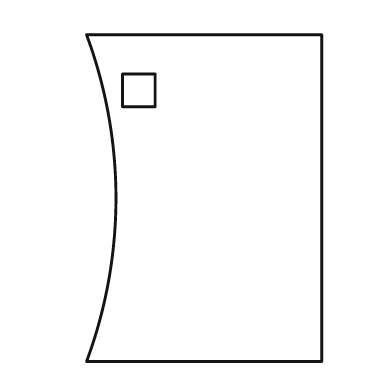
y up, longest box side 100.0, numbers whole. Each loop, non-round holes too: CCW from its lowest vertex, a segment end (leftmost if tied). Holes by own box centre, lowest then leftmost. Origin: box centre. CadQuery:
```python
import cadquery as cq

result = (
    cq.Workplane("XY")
    .moveTo(-36.0, -50.0)
    .lineTo(36.0, -50.0)
    .lineTo(36.0, 50.0)
    .lineTo(-36.0, 50.0)
    .threePointArc((-27.0, 0.0), (-36.0, -50.0))
    .close()
    .moveTo(-25.0, 28.0)
    .lineTo(-15.0, 28.0)
    .lineTo(-15.0, 38.0)
    .lineTo(-25.0, 38.0)
    .close()
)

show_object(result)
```